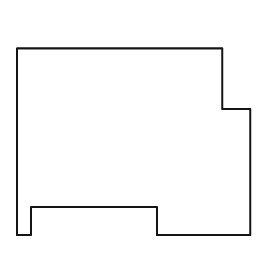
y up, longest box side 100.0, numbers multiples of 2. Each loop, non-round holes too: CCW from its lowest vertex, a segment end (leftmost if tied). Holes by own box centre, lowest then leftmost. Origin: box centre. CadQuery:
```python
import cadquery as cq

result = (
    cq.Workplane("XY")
    .moveTo(-50.0, -40.0)
    .lineTo(-44.0, -40.0)
    .lineTo(-44.0, -28.0)
    .lineTo(10.0, -28.0)
    .lineTo(10.0, -40.0)
    .lineTo(50.0, -40.0)
    .lineTo(50.0, 14.0)
    .lineTo(38.0, 14.0)
    .lineTo(38.0, 40.0)
    .lineTo(-50.0, 40.0)
    .close()
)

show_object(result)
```